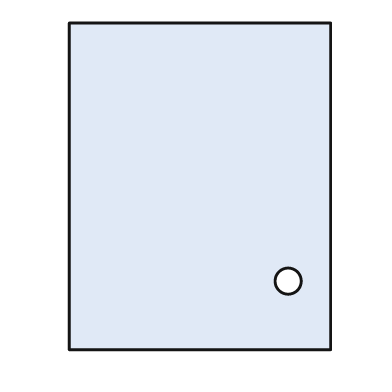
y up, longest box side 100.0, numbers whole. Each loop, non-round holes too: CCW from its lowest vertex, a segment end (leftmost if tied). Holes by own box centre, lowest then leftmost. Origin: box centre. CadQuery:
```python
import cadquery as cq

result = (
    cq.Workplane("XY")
    .moveTo(-40.0, -50.0)
    .lineTo(40.0, -50.0)
    .lineTo(40.0, 50.0)
    .lineTo(-40.0, 50.0)
    .close()
    .moveTo(27.0, -29.0)
    .circle(4.0)
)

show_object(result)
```